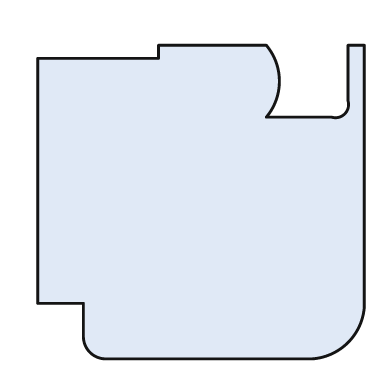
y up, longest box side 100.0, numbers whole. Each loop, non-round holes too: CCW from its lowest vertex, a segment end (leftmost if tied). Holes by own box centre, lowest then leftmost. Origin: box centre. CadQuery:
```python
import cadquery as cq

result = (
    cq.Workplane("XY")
    .moveTo(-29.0, -48.0)
    .lineTo(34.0, -48.0)
    .threePointArc((45.0, -43.0), (50.0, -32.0))
    .lineTo(50.0, 48.0)
    .lineTo(45.0, 48.0)
    .lineTo(45.0, 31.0)
    .threePointArc((44.0, 27.0), (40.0, 26.0))
    .lineTo(20.0, 26.0)
    .threePointArc((24.0, 37.0), (20.0, 48.0))
    .lineTo(-13.0, 48.0)
    .lineTo(-13.0, 44.0)
    .lineTo(-50.0, 44.0)
    .lineTo(-50.0, -31.0)
    .lineTo(-36.0, -31.0)
    .lineTo(-36.0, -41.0)
    .threePointArc((-34.0, -46.0), (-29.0, -48.0))
    .close()
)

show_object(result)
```